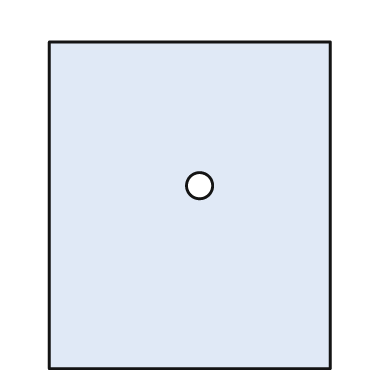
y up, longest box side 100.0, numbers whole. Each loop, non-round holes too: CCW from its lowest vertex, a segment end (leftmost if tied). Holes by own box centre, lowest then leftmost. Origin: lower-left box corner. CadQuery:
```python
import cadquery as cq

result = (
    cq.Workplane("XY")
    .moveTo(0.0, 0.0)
    .lineTo(86.0, 0.0)
    .lineTo(86.0, 100.0)
    .lineTo(0.0, 100.0)
    .close()
    .moveTo(46.0, 56.0)
    .circle(4.0)
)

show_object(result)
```